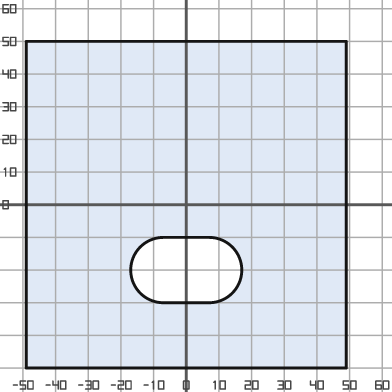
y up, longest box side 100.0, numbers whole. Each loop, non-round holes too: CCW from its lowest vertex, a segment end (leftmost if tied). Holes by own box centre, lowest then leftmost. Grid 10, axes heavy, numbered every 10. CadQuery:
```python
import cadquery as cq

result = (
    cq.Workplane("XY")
    .moveTo(-49.0, -50.0)
    .lineTo(49.0, -50.0)
    .lineTo(49.0, 50.0)
    .lineTo(-49.0, 50.0)
    .close()
    .moveTo(-7.0, -30.0)
    .lineTo(7.0, -30.0)
    .threePointArc((17.0, -20.0), (7.0, -10.0))
    .lineTo(-7.0, -10.0)
    .threePointArc((-17.0, -20.0), (-7.0, -30.0))
    .close()
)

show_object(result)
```